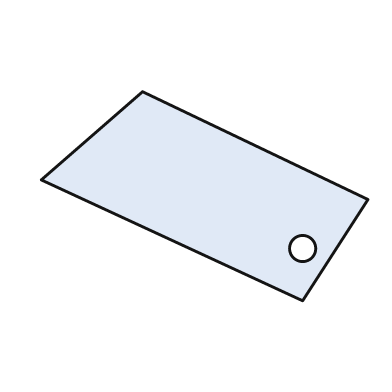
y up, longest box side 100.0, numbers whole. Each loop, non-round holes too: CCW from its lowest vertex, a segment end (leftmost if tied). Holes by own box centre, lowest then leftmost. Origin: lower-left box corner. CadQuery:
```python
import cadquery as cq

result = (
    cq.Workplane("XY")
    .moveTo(80.0, 0.0)
    .lineTo(100.0, 31.0)
    .lineTo(31.0, 64.0)
    .lineTo(0.0, 37.0)
    .close()
    .moveTo(80.0, 16.0)
    .circle(4.0)
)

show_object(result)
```